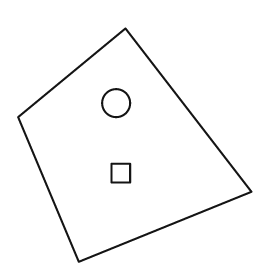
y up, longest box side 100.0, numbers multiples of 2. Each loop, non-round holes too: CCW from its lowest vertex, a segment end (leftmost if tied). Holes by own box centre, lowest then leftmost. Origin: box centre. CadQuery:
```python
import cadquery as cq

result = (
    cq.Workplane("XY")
    .moveTo(-24.0, -50.0)
    .lineTo(50.0, -20.0)
    .lineTo(-4.0, 50.0)
    .lineTo(-50.0, 12.0)
    .close()
    .moveTo(-10.0, -16.0)
    .lineTo(-2.0, -16.0)
    .lineTo(-2.0, -8.0)
    .lineTo(-10.0, -8.0)
    .close()
    .moveTo(-8.0, 18.0)
    .circle(6.0)
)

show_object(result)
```